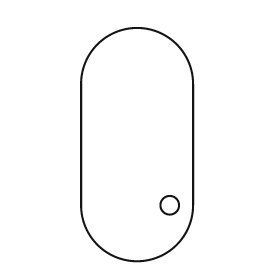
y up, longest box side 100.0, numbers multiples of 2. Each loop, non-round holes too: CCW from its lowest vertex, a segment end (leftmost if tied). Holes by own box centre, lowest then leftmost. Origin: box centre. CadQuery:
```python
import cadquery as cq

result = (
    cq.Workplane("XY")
    .moveTo(-24.0, -26.0)
    .threePointArc((0.0, -50.0), (24.0, -26.0))
    .lineTo(24.0, 26.0)
    .threePointArc((0.0, 50.0), (-24.0, 26.0))
    .close()
    .moveTo(14.0, -26.0)
    .circle(4.0)
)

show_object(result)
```